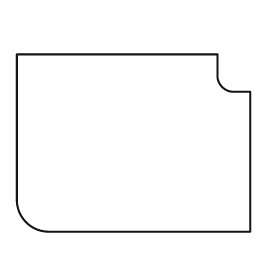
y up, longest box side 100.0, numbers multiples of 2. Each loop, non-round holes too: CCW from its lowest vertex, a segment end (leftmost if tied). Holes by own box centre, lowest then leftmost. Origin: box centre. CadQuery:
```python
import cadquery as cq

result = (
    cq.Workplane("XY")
    .moveTo(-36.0, -38.0)
    .lineTo(50.0, -38.0)
    .lineTo(50.0, 22.0)
    .lineTo(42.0, 22.0)
    .threePointArc((38.0, 24.0), (36.0, 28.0))
    .lineTo(36.0, 38.0)
    .lineTo(-50.0, 38.0)
    .lineTo(-50.0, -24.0)
    .threePointArc((-46.0, -34.0), (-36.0, -38.0))
    .close()
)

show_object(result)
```